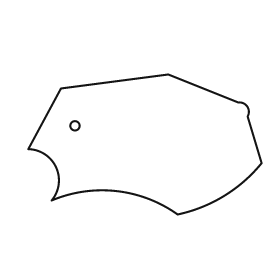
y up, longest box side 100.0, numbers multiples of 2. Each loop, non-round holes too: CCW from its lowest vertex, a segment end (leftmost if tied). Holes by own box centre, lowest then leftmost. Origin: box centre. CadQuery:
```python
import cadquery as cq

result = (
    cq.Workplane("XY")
    .moveTo(14.0, -30.0)
    .threePointArc((34.0, -22.0), (50.0, -8.0))
    .lineTo(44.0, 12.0)
    .threePointArc((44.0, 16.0), (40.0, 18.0))
    .lineTo(10.0, 30.0)
    .lineTo(-36.0, 24.0)
    .lineTo(-50.0, -2.0)
    .threePointArc((-38.0, -10.0), (-40.0, -24.0))
    .threePointArc((-12.0, -20.0), (14.0, -30.0))
    .close()
    .moveTo(-30.0, 8.0)
    .circle(2.0)
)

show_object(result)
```